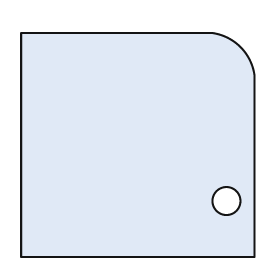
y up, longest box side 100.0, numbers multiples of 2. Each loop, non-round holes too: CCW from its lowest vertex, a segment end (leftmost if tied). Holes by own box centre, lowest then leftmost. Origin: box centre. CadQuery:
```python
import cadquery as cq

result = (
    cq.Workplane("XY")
    .moveTo(-50.0, -48.0)
    .lineTo(50.0, -48.0)
    .lineTo(50.0, 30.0)
    .threePointArc((44.0, 42.0), (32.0, 48.0))
    .lineTo(-50.0, 48.0)
    .close()
    .moveTo(38.0, -24.0)
    .circle(6.0)
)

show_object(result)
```